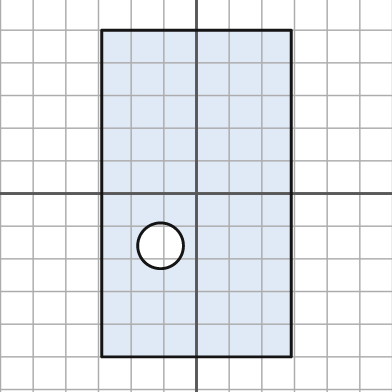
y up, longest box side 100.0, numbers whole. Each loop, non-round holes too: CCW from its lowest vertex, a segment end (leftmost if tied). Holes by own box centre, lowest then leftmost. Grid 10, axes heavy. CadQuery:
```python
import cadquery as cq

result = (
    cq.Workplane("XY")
    .moveTo(-29.0, -50.0)
    .lineTo(29.0, -50.0)
    .lineTo(29.0, 50.0)
    .lineTo(-29.0, 50.0)
    .close()
    .moveTo(-11.0, -16.0)
    .circle(7.0)
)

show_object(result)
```